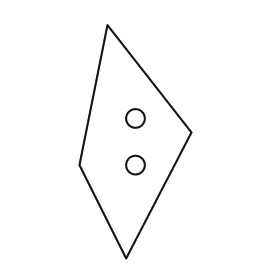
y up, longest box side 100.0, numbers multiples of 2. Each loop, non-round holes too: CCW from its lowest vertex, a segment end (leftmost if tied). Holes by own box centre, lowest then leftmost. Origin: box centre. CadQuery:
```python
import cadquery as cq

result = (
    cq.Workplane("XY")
    .moveTo(-4.0, -50.0)
    .lineTo(24.0, 4.0)
    .lineTo(-12.0, 50.0)
    .lineTo(-24.0, -10.0)
    .close()
    .moveTo(0.0, -10.0)
    .circle(4.0)
    .moveTo(0.0, 10.0)
    .circle(4.0)
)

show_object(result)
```